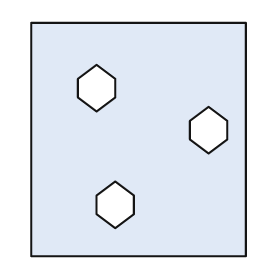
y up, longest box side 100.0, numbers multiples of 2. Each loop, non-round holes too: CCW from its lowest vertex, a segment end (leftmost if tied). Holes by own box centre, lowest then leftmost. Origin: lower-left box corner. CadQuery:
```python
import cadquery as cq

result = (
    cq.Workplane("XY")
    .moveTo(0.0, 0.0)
    .lineTo(92.0, 0.0)
    .lineTo(92.0, 100.0)
    .lineTo(0.0, 100.0)
    .close()
    .moveTo(36.0, 12.0)
    .lineTo(44.0, 18.0)
    .lineTo(44.0, 26.0)
    .lineTo(36.0, 32.0)
    .lineTo(28.0, 26.0)
    .lineTo(28.0, 18.0)
    .close()
    .moveTo(76.0, 44.0)
    .lineTo(84.0, 50.0)
    .lineTo(84.0, 58.0)
    .lineTo(76.0, 64.0)
    .lineTo(68.0, 58.0)
    .lineTo(68.0, 50.0)
    .close()
    .moveTo(28.0, 62.0)
    .lineTo(36.0, 68.0)
    .lineTo(36.0, 76.0)
    .lineTo(28.0, 82.0)
    .lineTo(20.0, 76.0)
    .lineTo(20.0, 68.0)
    .close()
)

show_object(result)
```